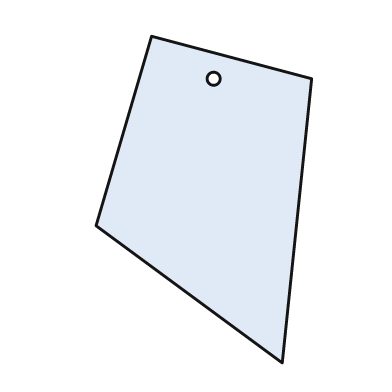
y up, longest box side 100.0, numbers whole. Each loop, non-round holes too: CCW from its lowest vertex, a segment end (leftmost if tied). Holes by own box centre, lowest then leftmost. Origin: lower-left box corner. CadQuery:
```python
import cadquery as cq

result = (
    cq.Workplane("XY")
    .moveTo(57.0, 0.0)
    .lineTo(66.0, 87.0)
    .lineTo(17.0, 100.0)
    .lineTo(0.0, 42.0)
    .close()
    .moveTo(36.0, 87.0)
    .circle(2.0)
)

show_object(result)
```